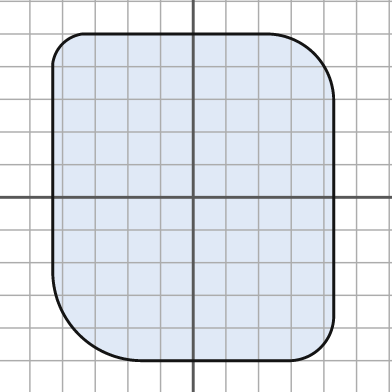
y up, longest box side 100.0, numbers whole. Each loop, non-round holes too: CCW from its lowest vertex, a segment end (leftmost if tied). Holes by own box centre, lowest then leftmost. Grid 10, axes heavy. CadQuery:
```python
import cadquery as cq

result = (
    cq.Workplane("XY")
    .moveTo(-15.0, -50.0)
    .lineTo(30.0, -50.0)
    .threePointArc((39.0, -46.0), (43.0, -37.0))
    .lineTo(43.0, 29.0)
    .threePointArc((37.0, 44.0), (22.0, 50.0))
    .lineTo(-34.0, 50.0)
    .threePointArc((-40.0, 47.0), (-43.0, 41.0))
    .lineTo(-43.0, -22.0)
    .threePointArc((-35.0, -42.0), (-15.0, -50.0))
    .close()
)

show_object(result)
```